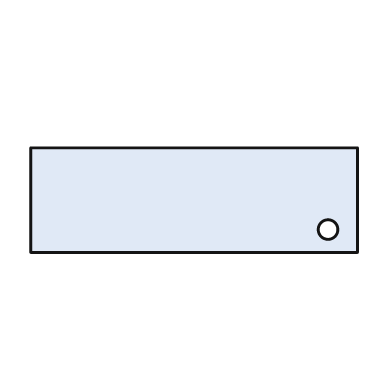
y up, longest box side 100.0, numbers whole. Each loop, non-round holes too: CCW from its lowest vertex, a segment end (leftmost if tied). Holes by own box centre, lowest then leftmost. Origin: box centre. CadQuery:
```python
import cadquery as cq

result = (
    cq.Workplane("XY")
    .moveTo(-50.0, -16.0)
    .lineTo(50.0, -16.0)
    .lineTo(50.0, 16.0)
    .lineTo(-50.0, 16.0)
    .close()
    .moveTo(41.0, -9.0)
    .circle(3.0)
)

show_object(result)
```